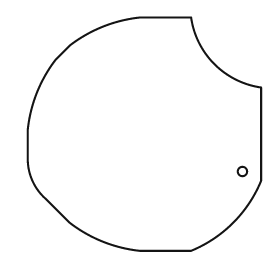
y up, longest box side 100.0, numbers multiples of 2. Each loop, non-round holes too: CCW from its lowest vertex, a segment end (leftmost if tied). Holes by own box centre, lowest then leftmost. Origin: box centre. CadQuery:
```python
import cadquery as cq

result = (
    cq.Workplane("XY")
    .moveTo(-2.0, -50.0)
    .lineTo(20.0, -50.0)
    .threePointArc((38.0, -38.0), (50.0, -20.0))
    .lineTo(50.0, 20.0)
    .threePointArc((30.0, 30.0), (20.0, 50.0))
    .lineTo(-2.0, 50.0)
    .threePointArc((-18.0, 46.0), (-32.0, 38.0))
    .lineTo(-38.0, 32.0)
    .threePointArc((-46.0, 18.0), (-50.0, 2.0))
    .lineTo(-50.0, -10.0)
    .threePointArc((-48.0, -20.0), (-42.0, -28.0))
    .lineTo(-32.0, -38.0)
    .threePointArc((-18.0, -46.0), (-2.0, -50.0))
    .close()
    .moveTo(42.0, -16.0)
    .circle(2.0)
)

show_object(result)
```